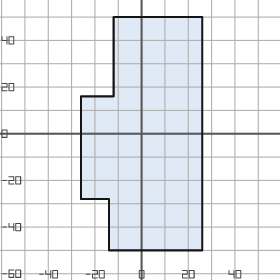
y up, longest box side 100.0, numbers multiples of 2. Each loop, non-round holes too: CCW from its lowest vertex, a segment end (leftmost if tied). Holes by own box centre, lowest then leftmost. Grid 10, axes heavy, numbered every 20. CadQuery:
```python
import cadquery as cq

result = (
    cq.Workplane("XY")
    .moveTo(-14.0, -50.0)
    .lineTo(26.0, -50.0)
    .lineTo(26.0, 50.0)
    .lineTo(-12.0, 50.0)
    .lineTo(-12.0, 16.0)
    .lineTo(-26.0, 16.0)
    .lineTo(-26.0, -28.0)
    .lineTo(-14.0, -28.0)
    .close()
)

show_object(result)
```